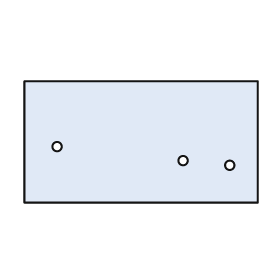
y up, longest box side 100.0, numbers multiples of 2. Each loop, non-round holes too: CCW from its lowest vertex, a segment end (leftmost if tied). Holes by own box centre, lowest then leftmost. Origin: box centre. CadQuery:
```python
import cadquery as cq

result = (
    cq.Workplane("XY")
    .moveTo(-50.0, -26.0)
    .lineTo(50.0, -26.0)
    .lineTo(50.0, 26.0)
    .lineTo(-50.0, 26.0)
    .close()
    .moveTo(38.0, -10.0)
    .circle(2.0)
    .moveTo(18.0, -8.0)
    .circle(2.0)
    .moveTo(-36.0, -2.0)
    .circle(2.0)
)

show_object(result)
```